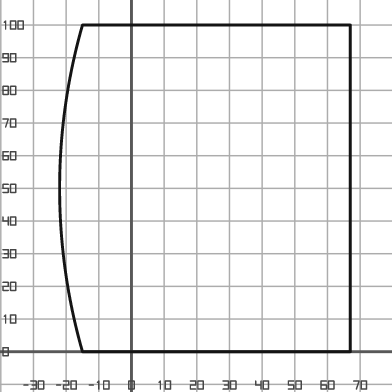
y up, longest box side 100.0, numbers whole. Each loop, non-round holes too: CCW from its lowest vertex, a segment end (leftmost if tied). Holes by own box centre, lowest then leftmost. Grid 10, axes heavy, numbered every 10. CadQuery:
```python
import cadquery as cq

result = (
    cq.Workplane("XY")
    .moveTo(-15.0, 0.0)
    .lineTo(67.0, 0.0)
    .lineTo(67.0, 100.0)
    .lineTo(-15.0, 100.0)
    .threePointArc((-22.0, 50.0), (-15.0, 0.0))
    .close()
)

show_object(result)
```